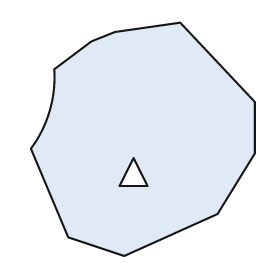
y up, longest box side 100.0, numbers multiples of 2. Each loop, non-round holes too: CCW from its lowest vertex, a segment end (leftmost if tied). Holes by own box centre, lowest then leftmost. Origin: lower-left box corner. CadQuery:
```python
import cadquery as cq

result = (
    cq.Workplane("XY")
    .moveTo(40.0, 0.0)
    .lineTo(80.0, 18.0)
    .lineTo(96.0, 44.0)
    .lineTo(96.0, 66.0)
    .lineTo(64.0, 100.0)
    .lineTo(36.0, 96.0)
    .lineTo(26.0, 92.0)
    .lineTo(10.0, 80.0)
    .threePointArc((8.0, 62.0), (0.0, 46.0))
    .lineTo(16.0, 8.0)
    .close()
    .moveTo(38.0, 30.0)
    .lineTo(50.0, 30.0)
    .lineTo(44.0, 42.0)
    .close()
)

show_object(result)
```